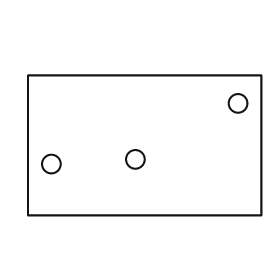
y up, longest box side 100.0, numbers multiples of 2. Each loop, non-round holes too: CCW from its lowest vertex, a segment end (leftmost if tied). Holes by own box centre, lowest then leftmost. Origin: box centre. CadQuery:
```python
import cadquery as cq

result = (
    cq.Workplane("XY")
    .moveTo(-50.0, -30.0)
    .lineTo(50.0, -30.0)
    .lineTo(50.0, 30.0)
    .lineTo(-50.0, 30.0)
    .close()
    .moveTo(-40.0, -8.0)
    .circle(4.0)
    .moveTo(-4.0, -6.0)
    .circle(4.0)
    .moveTo(40.0, 18.0)
    .circle(4.0)
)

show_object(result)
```